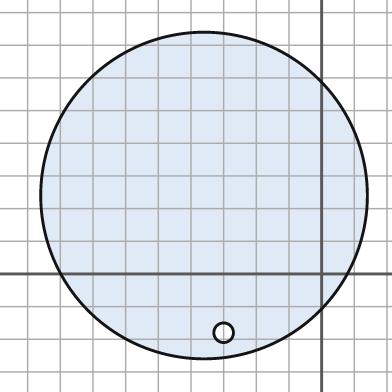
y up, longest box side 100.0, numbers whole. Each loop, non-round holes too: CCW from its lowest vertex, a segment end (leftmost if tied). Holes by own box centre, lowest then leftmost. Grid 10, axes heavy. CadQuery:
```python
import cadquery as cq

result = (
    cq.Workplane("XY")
    .moveTo(-36.0, 24.0)
    .circle(50.0)
    .moveTo(-30.0, -18.0)
    .circle(3.0)
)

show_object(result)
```